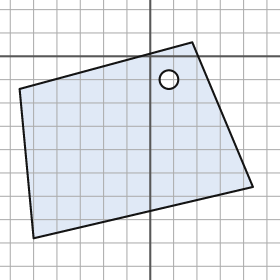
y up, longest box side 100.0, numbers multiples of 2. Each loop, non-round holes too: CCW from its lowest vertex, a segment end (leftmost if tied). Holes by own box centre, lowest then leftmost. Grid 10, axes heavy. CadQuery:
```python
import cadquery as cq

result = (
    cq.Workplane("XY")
    .moveTo(-50.0, -78.0)
    .lineTo(44.0, -56.0)
    .lineTo(18.0, 6.0)
    .lineTo(-56.0, -14.0)
    .close()
    .moveTo(8.0, -10.0)
    .circle(4.0)
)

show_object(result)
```